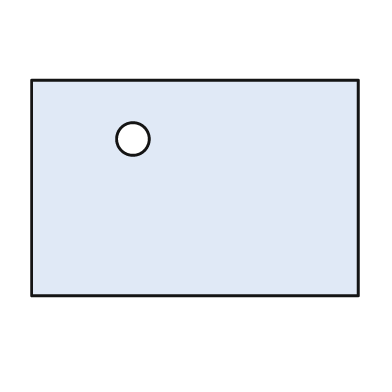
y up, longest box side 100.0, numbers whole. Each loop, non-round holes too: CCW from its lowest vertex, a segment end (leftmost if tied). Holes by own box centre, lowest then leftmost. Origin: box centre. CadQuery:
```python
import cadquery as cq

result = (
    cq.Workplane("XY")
    .moveTo(-50.0, -33.0)
    .lineTo(50.0, -33.0)
    .lineTo(50.0, 33.0)
    .lineTo(-50.0, 33.0)
    .close()
    .moveTo(-19.0, 15.0)
    .circle(5.0)
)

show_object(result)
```